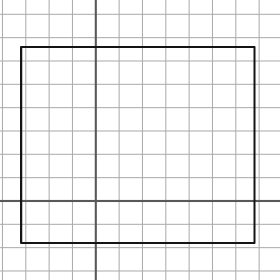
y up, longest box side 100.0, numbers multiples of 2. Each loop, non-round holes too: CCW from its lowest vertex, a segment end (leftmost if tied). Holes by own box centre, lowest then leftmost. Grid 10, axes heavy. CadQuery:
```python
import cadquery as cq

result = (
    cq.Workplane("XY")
    .moveTo(-32.0, -18.0)
    .lineTo(68.0, -18.0)
    .lineTo(68.0, 66.0)
    .lineTo(-32.0, 66.0)
    .close()
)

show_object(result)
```